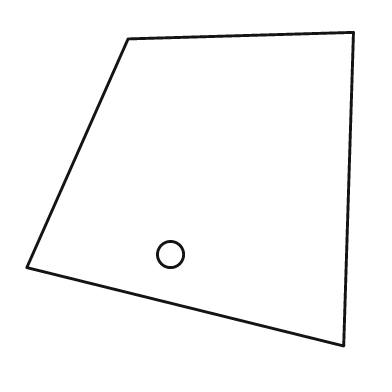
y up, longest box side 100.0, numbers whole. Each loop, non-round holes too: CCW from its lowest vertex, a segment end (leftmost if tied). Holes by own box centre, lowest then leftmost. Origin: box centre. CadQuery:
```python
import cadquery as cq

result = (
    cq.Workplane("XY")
    .moveTo(47.0, -48.0)
    .lineTo(50.0, 48.0)
    .lineTo(-19.0, 46.0)
    .lineTo(-50.0, -24.0)
    .close()
    .moveTo(-6.0, -20.0)
    .circle(4.0)
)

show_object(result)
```